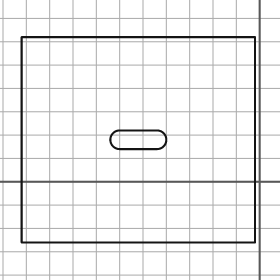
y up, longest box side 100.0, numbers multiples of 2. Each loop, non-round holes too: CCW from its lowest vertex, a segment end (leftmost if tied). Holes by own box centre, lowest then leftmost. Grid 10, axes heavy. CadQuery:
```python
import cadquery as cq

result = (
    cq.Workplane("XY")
    .moveTo(-102.0, -26.0)
    .lineTo(-2.0, -26.0)
    .lineTo(-2.0, 62.0)
    .lineTo(-102.0, 62.0)
    .close()
    .moveTo(-60.0, 14.0)
    .lineTo(-44.0, 14.0)
    .threePointArc((-40.0, 18.0), (-44.0, 22.0))
    .lineTo(-60.0, 22.0)
    .threePointArc((-64.0, 18.0), (-60.0, 14.0))
    .close()
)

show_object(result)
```